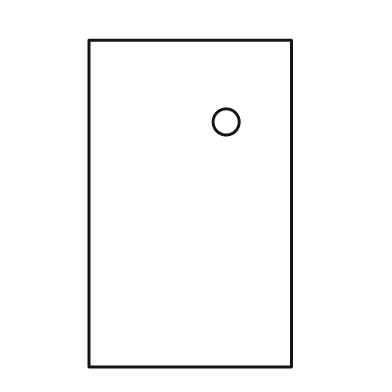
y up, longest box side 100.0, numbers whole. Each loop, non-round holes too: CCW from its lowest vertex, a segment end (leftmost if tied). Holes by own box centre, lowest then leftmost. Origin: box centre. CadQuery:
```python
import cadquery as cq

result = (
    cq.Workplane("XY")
    .moveTo(-31.0, -50.0)
    .lineTo(31.0, -50.0)
    .lineTo(31.0, 50.0)
    .lineTo(-31.0, 50.0)
    .close()
    .moveTo(11.0, 25.0)
    .circle(4.0)
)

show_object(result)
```